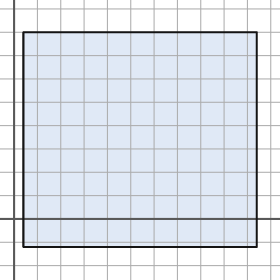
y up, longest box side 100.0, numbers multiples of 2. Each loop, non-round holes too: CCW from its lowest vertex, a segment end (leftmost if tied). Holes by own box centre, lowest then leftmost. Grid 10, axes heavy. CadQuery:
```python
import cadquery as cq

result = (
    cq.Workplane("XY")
    .moveTo(4.0, -12.0)
    .lineTo(104.0, -12.0)
    .lineTo(104.0, 80.0)
    .lineTo(4.0, 80.0)
    .close()
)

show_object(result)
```